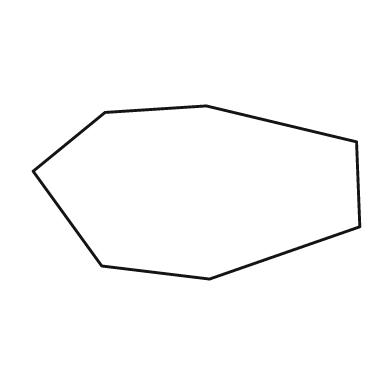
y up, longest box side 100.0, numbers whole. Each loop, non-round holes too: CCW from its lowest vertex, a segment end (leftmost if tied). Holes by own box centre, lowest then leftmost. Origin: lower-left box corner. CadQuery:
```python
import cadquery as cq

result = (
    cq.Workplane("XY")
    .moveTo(54.0, 0.0)
    .lineTo(100.0, 16.0)
    .lineTo(99.0, 42.0)
    .lineTo(53.0, 53.0)
    .lineTo(22.0, 51.0)
    .lineTo(0.0, 33.0)
    .lineTo(21.0, 4.0)
    .close()
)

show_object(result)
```